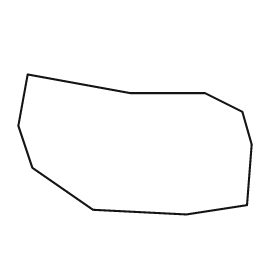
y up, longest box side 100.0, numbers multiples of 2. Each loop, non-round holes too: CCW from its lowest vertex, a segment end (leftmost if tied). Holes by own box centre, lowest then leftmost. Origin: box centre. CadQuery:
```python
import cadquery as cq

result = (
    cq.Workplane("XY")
    .moveTo(22.0, -30.0)
    .lineTo(48.0, -26.0)
    .lineTo(50.0, 0.0)
    .lineTo(46.0, 14.0)
    .lineTo(30.0, 22.0)
    .lineTo(-2.0, 22.0)
    .lineTo(-46.0, 30.0)
    .lineTo(-50.0, 8.0)
    .lineTo(-44.0, -10.0)
    .lineTo(-18.0, -28.0)
    .close()
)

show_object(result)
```